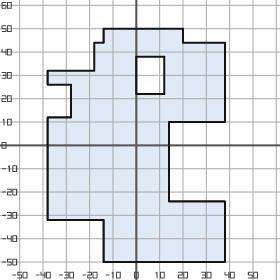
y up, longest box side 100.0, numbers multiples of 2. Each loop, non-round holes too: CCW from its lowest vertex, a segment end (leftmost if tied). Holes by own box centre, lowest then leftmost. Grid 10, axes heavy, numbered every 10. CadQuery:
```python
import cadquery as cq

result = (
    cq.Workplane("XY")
    .moveTo(-14.0, -50.0)
    .lineTo(38.0, -50.0)
    .lineTo(38.0, -24.0)
    .lineTo(14.0, -24.0)
    .lineTo(14.0, 10.0)
    .lineTo(38.0, 10.0)
    .lineTo(38.0, 44.0)
    .lineTo(20.0, 44.0)
    .lineTo(20.0, 50.0)
    .lineTo(-14.0, 50.0)
    .lineTo(-14.0, 44.0)
    .lineTo(-18.0, 44.0)
    .lineTo(-18.0, 32.0)
    .lineTo(-38.0, 32.0)
    .lineTo(-38.0, 26.0)
    .lineTo(-28.0, 26.0)
    .lineTo(-28.0, 12.0)
    .lineTo(-38.0, 12.0)
    .lineTo(-38.0, -32.0)
    .lineTo(-14.0, -32.0)
    .close()
    .moveTo(0.0, 22.0)
    .lineTo(12.0, 22.0)
    .lineTo(12.0, 38.0)
    .lineTo(0.0, 38.0)
    .close()
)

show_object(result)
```